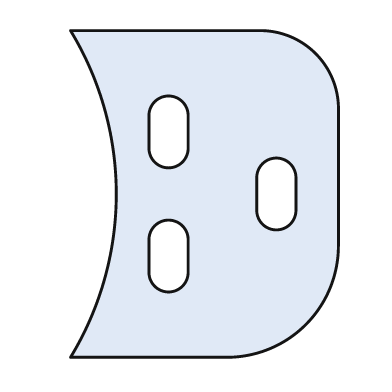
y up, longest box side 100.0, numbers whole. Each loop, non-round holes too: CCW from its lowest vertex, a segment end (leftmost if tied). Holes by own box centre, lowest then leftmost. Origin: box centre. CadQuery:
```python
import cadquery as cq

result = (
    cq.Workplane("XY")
    .moveTo(-41.0, -50.0)
    .lineTo(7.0, -50.0)
    .threePointArc((31.0, -40.0), (41.0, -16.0))
    .lineTo(41.0, 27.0)
    .threePointArc((34.0, 43.0), (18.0, 50.0))
    .lineTo(-41.0, 50.0)
    .threePointArc((-27.0, 0.0), (-41.0, -50.0))
    .close()
    .moveTo(-17.0, -24.0)
    .threePointArc((-11.0, -30.0), (-5.0, -24.0))
    .lineTo(-5.0, -14.0)
    .threePointArc((-11.0, -8.0), (-17.0, -14.0))
    .close()
    .moveTo(16.0, -5.0)
    .threePointArc((22.0, -11.0), (28.0, -5.0))
    .lineTo(28.0, 5.0)
    .threePointArc((22.0, 11.0), (16.0, 5.0))
    .close()
    .moveTo(-17.0, 14.0)
    .threePointArc((-11.0, 8.0), (-5.0, 14.0))
    .lineTo(-5.0, 24.0)
    .threePointArc((-11.0, 30.0), (-17.0, 24.0))
    .close()
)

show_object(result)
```